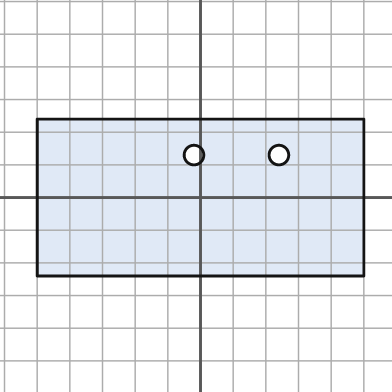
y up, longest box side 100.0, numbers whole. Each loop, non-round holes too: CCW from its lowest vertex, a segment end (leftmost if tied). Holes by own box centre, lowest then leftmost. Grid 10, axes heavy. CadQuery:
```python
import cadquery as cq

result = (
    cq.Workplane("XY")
    .moveTo(-50.0, -24.0)
    .lineTo(50.0, -24.0)
    .lineTo(50.0, 24.0)
    .lineTo(-50.0, 24.0)
    .close()
    .moveTo(-2.0, 13.0)
    .circle(3.0)
    .moveTo(24.0, 13.0)
    .circle(3.0)
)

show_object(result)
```